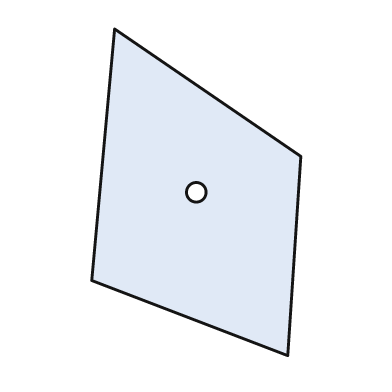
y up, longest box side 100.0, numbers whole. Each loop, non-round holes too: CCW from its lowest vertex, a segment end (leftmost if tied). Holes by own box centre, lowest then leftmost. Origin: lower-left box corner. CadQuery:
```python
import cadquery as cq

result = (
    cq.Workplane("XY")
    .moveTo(60.0, 0.0)
    .lineTo(64.0, 61.0)
    .lineTo(7.0, 100.0)
    .lineTo(0.0, 23.0)
    .close()
    .moveTo(32.0, 50.0)
    .circle(3.0)
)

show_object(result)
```